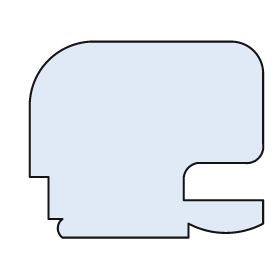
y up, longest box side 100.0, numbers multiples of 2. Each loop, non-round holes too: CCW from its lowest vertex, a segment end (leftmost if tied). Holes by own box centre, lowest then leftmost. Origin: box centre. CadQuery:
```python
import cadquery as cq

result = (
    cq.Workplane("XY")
    .moveTo(-36.0, -42.0)
    .lineTo(18.0, -42.0)
    .lineTo(18.0, -36.0)
    .threePointArc((34.0, -40.0), (50.0, -36.0))
    .lineTo(50.0, -26.0)
    .lineTo(16.0, -26.0)
    .lineTo(16.0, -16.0)
    .threePointArc((18.0, -12.0), (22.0, -10.0))
    .lineTo(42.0, -10.0)
    .threePointArc((48.0, -8.0), (50.0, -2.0))
    .lineTo(50.0, 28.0)
    .threePointArc((46.0, 38.0), (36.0, 42.0))
    .lineTo(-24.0, 42.0)
    .threePointArc((-42.0, 34.0), (-50.0, 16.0))
    .lineTo(-50.0, -16.0)
    .lineTo(-42.0, -16.0)
    .lineTo(-42.0, -34.0)
    .lineTo(-36.0, -34.0)
    .threePointArc((-38.0, -38.0), (-36.0, -42.0))
    .close()
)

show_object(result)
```